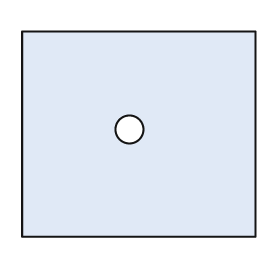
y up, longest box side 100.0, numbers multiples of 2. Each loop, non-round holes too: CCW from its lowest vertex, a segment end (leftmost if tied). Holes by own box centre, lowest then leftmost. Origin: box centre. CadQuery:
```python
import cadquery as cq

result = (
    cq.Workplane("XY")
    .moveTo(-50.0, -44.0)
    .lineTo(50.0, -44.0)
    .lineTo(50.0, 44.0)
    .lineTo(-50.0, 44.0)
    .close()
    .moveTo(-4.0, 2.0)
    .circle(6.0)
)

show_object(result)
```